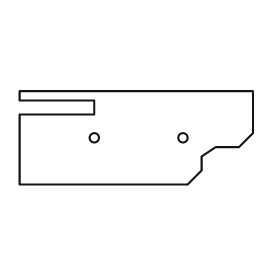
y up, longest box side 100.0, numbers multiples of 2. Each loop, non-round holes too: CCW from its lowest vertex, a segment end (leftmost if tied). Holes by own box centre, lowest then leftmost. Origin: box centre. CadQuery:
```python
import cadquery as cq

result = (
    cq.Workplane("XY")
    .moveTo(-50.0, -20.0)
    .lineTo(22.0, -20.0)
    .lineTo(28.0, -14.0)
    .lineTo(28.0, -8.0)
    .lineTo(34.0, -4.0)
    .lineTo(44.0, -4.0)
    .lineTo(50.0, 2.0)
    .lineTo(50.0, 20.0)
    .lineTo(-50.0, 20.0)
    .lineTo(-50.0, 16.0)
    .lineTo(-18.0, 16.0)
    .lineTo(-18.0, 10.0)
    .lineTo(-50.0, 10.0)
    .close()
    .moveTo(-18.0, 0.0)
    .circle(2.0)
    .moveTo(20.0, 0.0)
    .circle(2.0)
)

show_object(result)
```